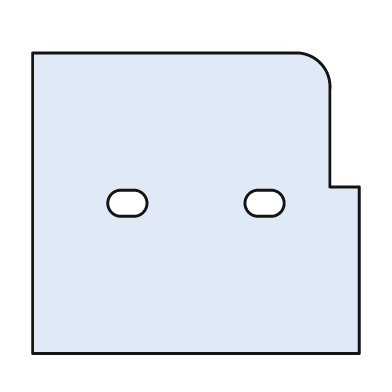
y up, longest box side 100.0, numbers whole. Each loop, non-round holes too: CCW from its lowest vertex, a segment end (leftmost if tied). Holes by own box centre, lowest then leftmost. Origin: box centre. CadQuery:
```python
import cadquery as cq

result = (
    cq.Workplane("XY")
    .moveTo(-50.0, -46.0)
    .lineTo(50.0, -46.0)
    .lineTo(50.0, 5.0)
    .lineTo(41.0, 5.0)
    .lineTo(41.0, 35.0)
    .threePointArc((38.0, 43.0), (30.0, 46.0))
    .lineTo(-50.0, 46.0)
    .close()
    .moveTo(-23.0, -4.0)
    .lineTo(-19.0, -4.0)
    .threePointArc((-15.0, 0.0), (-19.0, 4.0))
    .lineTo(-23.0, 4.0)
    .threePointArc((-27.0, 0.0), (-23.0, -4.0))
    .close()
    .moveTo(19.0, -4.0)
    .lineTo(23.0, -4.0)
    .threePointArc((27.0, 0.0), (23.0, 4.0))
    .lineTo(19.0, 4.0)
    .threePointArc((15.0, 0.0), (19.0, -4.0))
    .close()
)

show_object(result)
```